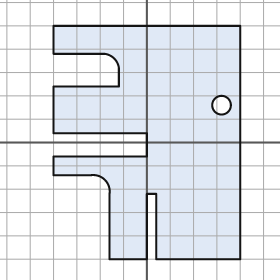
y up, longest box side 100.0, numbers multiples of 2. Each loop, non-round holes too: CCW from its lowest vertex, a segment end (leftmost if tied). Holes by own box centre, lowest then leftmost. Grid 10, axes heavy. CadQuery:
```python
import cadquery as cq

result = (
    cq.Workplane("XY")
    .moveTo(-16.0, -50.0)
    .lineTo(0.0, -50.0)
    .lineTo(0.0, -22.0)
    .lineTo(4.0, -22.0)
    .lineTo(4.0, -50.0)
    .lineTo(40.0, -50.0)
    .lineTo(40.0, 50.0)
    .lineTo(-40.0, 50.0)
    .lineTo(-40.0, 38.0)
    .lineTo(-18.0, 38.0)
    .threePointArc((-14.0, 36.0), (-12.0, 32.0))
    .lineTo(-12.0, 24.0)
    .lineTo(-40.0, 24.0)
    .lineTo(-40.0, 4.0)
    .lineTo(0.0, 4.0)
    .lineTo(0.0, -6.0)
    .lineTo(-40.0, -6.0)
    .lineTo(-40.0, -14.0)
    .lineTo(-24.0, -14.0)
    .threePointArc((-18.0, -16.0), (-16.0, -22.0))
    .close()
    .moveTo(32.0, 16.0)
    .circle(4.0)
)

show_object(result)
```